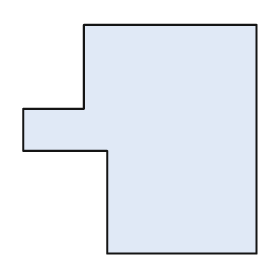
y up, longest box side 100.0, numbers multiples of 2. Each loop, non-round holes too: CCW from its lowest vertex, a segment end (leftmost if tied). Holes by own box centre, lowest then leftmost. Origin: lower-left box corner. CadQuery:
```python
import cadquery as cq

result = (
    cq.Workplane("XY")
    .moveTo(36.0, 0.0)
    .lineTo(100.0, 0.0)
    .lineTo(100.0, 98.0)
    .lineTo(26.0, 98.0)
    .lineTo(26.0, 62.0)
    .lineTo(0.0, 62.0)
    .lineTo(0.0, 44.0)
    .lineTo(36.0, 44.0)
    .close()
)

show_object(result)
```